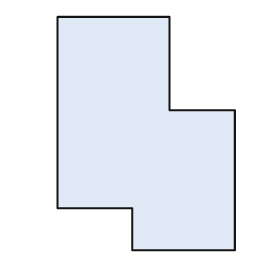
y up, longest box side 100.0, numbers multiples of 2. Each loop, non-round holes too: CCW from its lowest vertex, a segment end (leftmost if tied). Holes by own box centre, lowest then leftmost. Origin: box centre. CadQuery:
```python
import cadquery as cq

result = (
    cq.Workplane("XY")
    .moveTo(-6.0, -50.0)
    .lineTo(38.0, -50.0)
    .lineTo(38.0, 10.0)
    .lineTo(10.0, 10.0)
    .lineTo(10.0, 50.0)
    .lineTo(-38.0, 50.0)
    .lineTo(-38.0, -32.0)
    .lineTo(-6.0, -32.0)
    .close()
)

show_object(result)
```